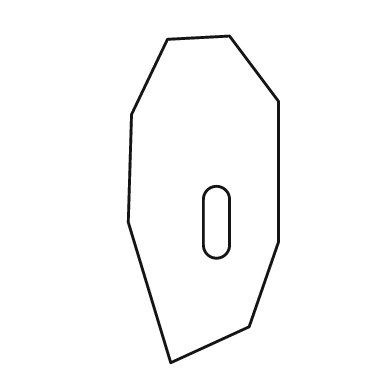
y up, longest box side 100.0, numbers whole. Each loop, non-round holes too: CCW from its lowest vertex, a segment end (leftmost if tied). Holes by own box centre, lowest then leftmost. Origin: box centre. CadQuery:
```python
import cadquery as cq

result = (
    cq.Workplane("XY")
    .moveTo(-10.0, -50.0)
    .lineTo(14.0, -39.0)
    .lineTo(23.0, -13.0)
    .lineTo(23.0, 30.0)
    .lineTo(8.0, 50.0)
    .lineTo(-11.0, 49.0)
    .lineTo(-22.0, 26.0)
    .lineTo(-23.0, -7.0)
    .close()
    .moveTo(0.0, -14.0)
    .threePointArc((4.0, -18.0), (8.0, -14.0))
    .lineTo(8.0, 0.0)
    .threePointArc((4.0, 4.0), (0.0, 0.0))
    .close()
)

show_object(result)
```